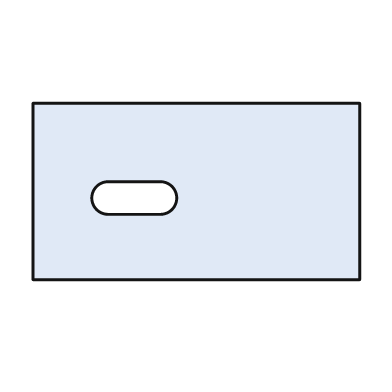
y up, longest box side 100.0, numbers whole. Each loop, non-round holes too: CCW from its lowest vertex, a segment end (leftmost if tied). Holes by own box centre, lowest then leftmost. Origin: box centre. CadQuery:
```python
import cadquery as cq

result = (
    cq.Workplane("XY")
    .moveTo(-50.0, -27.0)
    .lineTo(50.0, -27.0)
    .lineTo(50.0, 27.0)
    .lineTo(-50.0, 27.0)
    .close()
    .moveTo(-27.0, -7.0)
    .lineTo(-11.0, -7.0)
    .threePointArc((-6.0, -2.0), (-11.0, 3.0))
    .lineTo(-27.0, 3.0)
    .threePointArc((-32.0, -2.0), (-27.0, -7.0))
    .close()
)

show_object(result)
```